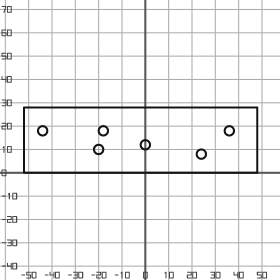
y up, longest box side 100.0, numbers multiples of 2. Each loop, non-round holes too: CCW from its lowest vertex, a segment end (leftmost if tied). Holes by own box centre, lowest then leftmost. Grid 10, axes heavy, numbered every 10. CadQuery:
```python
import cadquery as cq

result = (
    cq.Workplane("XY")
    .moveTo(-52.0, 0.0)
    .lineTo(48.0, 0.0)
    .lineTo(48.0, 28.0)
    .lineTo(-52.0, 28.0)
    .close()
    .moveTo(24.0, 8.0)
    .circle(2.0)
    .moveTo(-20.0, 10.0)
    .circle(2.0)
    .moveTo(0.0, 12.0)
    .circle(2.0)
    .moveTo(-44.0, 18.0)
    .circle(2.0)
    .moveTo(-18.0, 18.0)
    .circle(2.0)
    .moveTo(36.0, 18.0)
    .circle(2.0)
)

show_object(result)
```